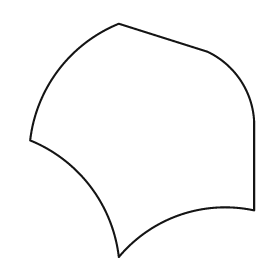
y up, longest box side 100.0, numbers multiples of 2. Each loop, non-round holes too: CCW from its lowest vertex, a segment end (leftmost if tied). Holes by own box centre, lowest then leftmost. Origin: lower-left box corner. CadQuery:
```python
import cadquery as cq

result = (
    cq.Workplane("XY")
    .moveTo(38.0, 0.0)
    .threePointArc((64.0, 18.0), (96.0, 20.0))
    .lineTo(96.0, 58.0)
    .threePointArc((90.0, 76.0), (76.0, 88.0))
    .lineTo(38.0, 100.0)
    .threePointArc((12.0, 80.0), (0.0, 50.0))
    .threePointArc((26.0, 30.0), (38.0, 0.0))
    .close()
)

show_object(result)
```